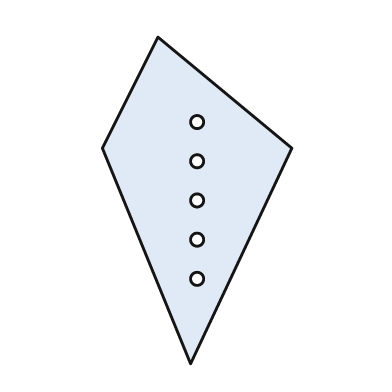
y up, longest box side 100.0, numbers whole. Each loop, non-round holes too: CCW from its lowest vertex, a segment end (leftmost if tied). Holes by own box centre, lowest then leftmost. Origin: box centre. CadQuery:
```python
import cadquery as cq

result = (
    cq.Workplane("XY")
    .moveTo(-2.0, -50.0)
    .lineTo(29.0, 16.0)
    .lineTo(-12.0, 50.0)
    .lineTo(-29.0, 16.0)
    .close()
    .moveTo(0.0, -24.0)
    .circle(2.0)
    .moveTo(0.0, -12.0)
    .circle(2.0)
    .moveTo(0.0, 0.0)
    .circle(2.0)
    .moveTo(0.0, 12.0)
    .circle(2.0)
    .moveTo(0.0, 24.0)
    .circle(2.0)
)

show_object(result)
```